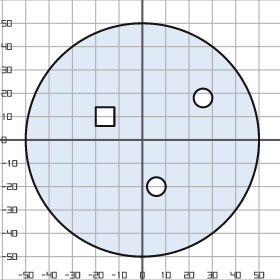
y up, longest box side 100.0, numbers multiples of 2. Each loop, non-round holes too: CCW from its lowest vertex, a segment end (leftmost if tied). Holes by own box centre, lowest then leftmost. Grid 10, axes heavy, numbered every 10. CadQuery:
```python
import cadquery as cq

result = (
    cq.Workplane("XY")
    .moveTo(0.0, 0.0)
    .circle(50.0)
    .moveTo(6.0, -20.0)
    .circle(4.0)
    .moveTo(-20.0, 6.0)
    .lineTo(-12.0, 6.0)
    .lineTo(-12.0, 14.0)
    .lineTo(-20.0, 14.0)
    .close()
    .moveTo(26.0, 18.0)
    .circle(4.0)
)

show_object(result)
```